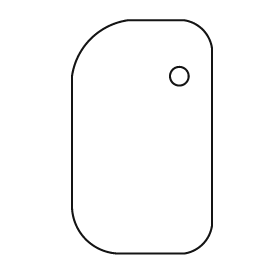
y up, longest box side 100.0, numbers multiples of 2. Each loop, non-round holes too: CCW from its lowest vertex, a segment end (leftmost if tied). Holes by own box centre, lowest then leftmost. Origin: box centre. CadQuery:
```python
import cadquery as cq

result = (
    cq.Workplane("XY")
    .moveTo(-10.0, -50.0)
    .lineTo(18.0, -50.0)
    .threePointArc((26.0, -46.0), (30.0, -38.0))
    .lineTo(30.0, 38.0)
    .threePointArc((26.0, 46.0), (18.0, 50.0))
    .lineTo(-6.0, 50.0)
    .threePointArc((-22.0, 42.0), (-30.0, 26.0))
    .lineTo(-30.0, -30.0)
    .threePointArc((-24.0, -44.0), (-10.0, -50.0))
    .close()
    .moveTo(16.0, 26.0)
    .circle(4.0)
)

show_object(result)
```